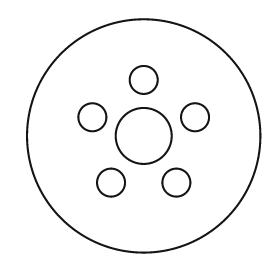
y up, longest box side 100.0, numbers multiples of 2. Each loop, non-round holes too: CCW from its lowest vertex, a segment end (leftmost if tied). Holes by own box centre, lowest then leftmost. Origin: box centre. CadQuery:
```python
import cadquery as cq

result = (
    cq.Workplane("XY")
    .moveTo(0.0, 0.0)
    .circle(50.0)
    .moveTo(-14.0, -20.0)
    .circle(6.0)
    .moveTo(14.0, -20.0)
    .circle(6.0)
    .moveTo(0.0, 0.0)
    .circle(12.0)
    .moveTo(-22.0, 8.0)
    .circle(6.0)
    .moveTo(22.0, 8.0)
    .circle(6.0)
    .moveTo(0.0, 24.0)
    .circle(6.0)
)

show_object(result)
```